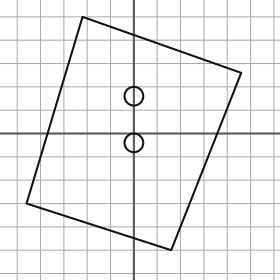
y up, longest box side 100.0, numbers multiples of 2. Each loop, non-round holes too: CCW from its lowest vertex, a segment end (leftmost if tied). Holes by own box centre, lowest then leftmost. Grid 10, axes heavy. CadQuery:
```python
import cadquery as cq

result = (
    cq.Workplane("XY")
    .moveTo(16.0, -50.0)
    .lineTo(46.0, 26.0)
    .lineTo(-22.0, 50.0)
    .lineTo(-46.0, -30.0)
    .close()
    .moveTo(0.0, -4.0)
    .circle(4.0)
    .moveTo(0.0, 16.0)
    .circle(4.0)
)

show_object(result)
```